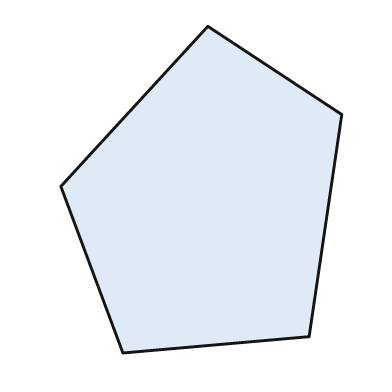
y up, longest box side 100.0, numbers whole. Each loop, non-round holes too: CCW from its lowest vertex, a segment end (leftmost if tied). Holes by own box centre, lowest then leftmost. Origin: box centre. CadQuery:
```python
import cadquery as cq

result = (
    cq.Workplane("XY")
    .moveTo(-24.0, -50.0)
    .lineTo(33.0, -45.0)
    .lineTo(43.0, 23.0)
    .lineTo(2.0, 50.0)
    .lineTo(-43.0, 1.0)
    .close()
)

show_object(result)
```